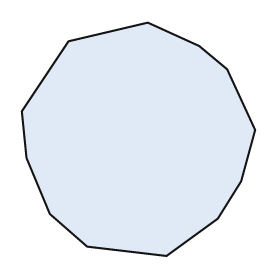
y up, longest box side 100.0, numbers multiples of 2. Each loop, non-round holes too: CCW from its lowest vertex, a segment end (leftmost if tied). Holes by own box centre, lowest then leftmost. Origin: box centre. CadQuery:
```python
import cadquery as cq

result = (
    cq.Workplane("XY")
    .moveTo(12.0, -50.0)
    .lineTo(34.0, -34.0)
    .lineTo(44.0, -18.0)
    .lineTo(50.0, 4.0)
    .lineTo(38.0, 30.0)
    .lineTo(26.0, 40.0)
    .lineTo(4.0, 50.0)
    .lineTo(-30.0, 42.0)
    .lineTo(-50.0, 12.0)
    .lineTo(-48.0, -8.0)
    .lineTo(-38.0, -32.0)
    .lineTo(-22.0, -46.0)
    .close()
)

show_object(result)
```